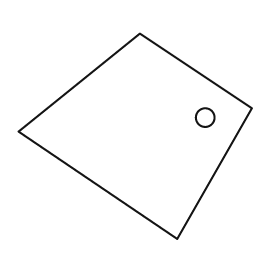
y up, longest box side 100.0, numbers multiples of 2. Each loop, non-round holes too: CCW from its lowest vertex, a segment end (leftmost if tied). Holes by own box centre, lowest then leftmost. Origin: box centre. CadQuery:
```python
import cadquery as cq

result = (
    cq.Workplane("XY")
    .moveTo(18.0, -44.0)
    .lineTo(50.0, 12.0)
    .lineTo(2.0, 44.0)
    .lineTo(-50.0, 2.0)
    .close()
    .moveTo(30.0, 8.0)
    .circle(4.0)
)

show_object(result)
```